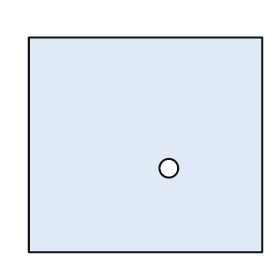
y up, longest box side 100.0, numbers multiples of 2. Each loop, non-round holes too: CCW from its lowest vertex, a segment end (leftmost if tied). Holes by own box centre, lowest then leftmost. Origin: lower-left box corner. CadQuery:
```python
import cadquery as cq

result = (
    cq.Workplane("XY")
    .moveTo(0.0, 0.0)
    .lineTo(100.0, 0.0)
    .lineTo(100.0, 92.0)
    .lineTo(0.0, 92.0)
    .close()
    .moveTo(60.0, 36.0)
    .circle(4.0)
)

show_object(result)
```